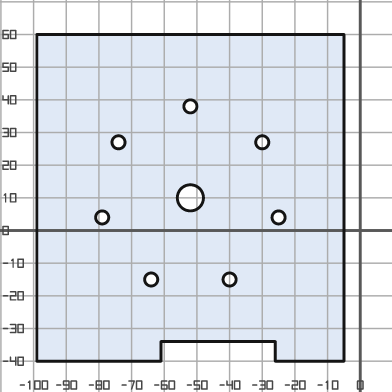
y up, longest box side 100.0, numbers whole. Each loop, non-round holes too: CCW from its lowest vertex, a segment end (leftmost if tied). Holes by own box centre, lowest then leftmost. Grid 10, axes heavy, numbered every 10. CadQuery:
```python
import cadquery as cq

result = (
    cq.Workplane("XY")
    .moveTo(-99.0, -40.0)
    .lineTo(-61.0, -40.0)
    .lineTo(-61.0, -34.0)
    .lineTo(-26.0, -34.0)
    .lineTo(-26.0, -40.0)
    .lineTo(-5.0, -40.0)
    .lineTo(-5.0, 60.0)
    .lineTo(-99.0, 60.0)
    .close()
    .moveTo(-64.0, -15.0)
    .circle(2.0)
    .moveTo(-40.0, -15.0)
    .circle(2.0)
    .moveTo(-79.0, 4.0)
    .circle(2.0)
    .moveTo(-25.0, 4.0)
    .circle(2.0)
    .moveTo(-52.0, 10.0)
    .circle(4.0)
    .moveTo(-74.0, 27.0)
    .circle(2.0)
    .moveTo(-30.0, 27.0)
    .circle(2.0)
    .moveTo(-52.0, 38.0)
    .circle(2.0)
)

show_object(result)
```